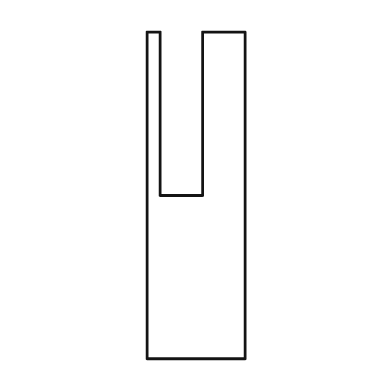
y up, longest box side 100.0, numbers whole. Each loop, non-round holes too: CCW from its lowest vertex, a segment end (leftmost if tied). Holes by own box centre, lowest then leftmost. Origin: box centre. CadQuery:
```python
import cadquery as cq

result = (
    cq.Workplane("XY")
    .moveTo(-15.0, -50.0)
    .lineTo(15.0, -50.0)
    .lineTo(15.0, 50.0)
    .lineTo(2.0, 50.0)
    .lineTo(2.0, 0.0)
    .lineTo(-11.0, 0.0)
    .lineTo(-11.0, 50.0)
    .lineTo(-15.0, 50.0)
    .close()
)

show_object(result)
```